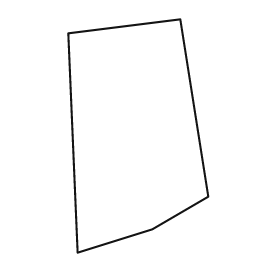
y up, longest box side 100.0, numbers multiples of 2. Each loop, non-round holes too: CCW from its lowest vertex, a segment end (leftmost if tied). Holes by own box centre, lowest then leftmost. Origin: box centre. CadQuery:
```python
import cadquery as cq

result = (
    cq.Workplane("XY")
    .moveTo(-26.0, -50.0)
    .lineTo(6.0, -40.0)
    .lineTo(30.0, -26.0)
    .lineTo(18.0, 50.0)
    .lineTo(-30.0, 44.0)
    .close()
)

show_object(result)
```